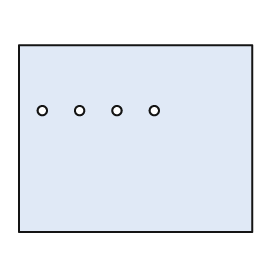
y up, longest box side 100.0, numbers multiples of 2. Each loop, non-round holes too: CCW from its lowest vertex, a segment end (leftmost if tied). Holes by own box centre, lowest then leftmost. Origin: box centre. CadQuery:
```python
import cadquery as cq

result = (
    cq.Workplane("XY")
    .moveTo(-50.0, -40.0)
    .lineTo(50.0, -40.0)
    .lineTo(50.0, 40.0)
    .lineTo(-50.0, 40.0)
    .close()
    .moveTo(-40.0, 12.0)
    .circle(2.0)
    .moveTo(-24.0, 12.0)
    .circle(2.0)
    .moveTo(-8.0, 12.0)
    .circle(2.0)
    .moveTo(8.0, 12.0)
    .circle(2.0)
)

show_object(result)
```